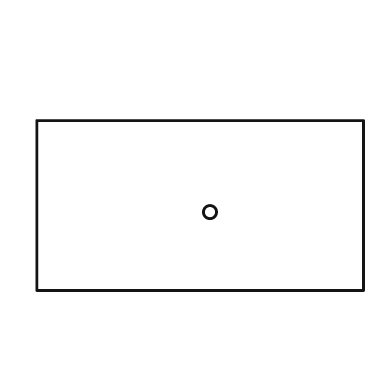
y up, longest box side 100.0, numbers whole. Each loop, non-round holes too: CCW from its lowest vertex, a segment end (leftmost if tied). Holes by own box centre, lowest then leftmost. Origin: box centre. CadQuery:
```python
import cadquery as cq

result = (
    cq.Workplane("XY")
    .moveTo(-50.0, -26.0)
    .lineTo(50.0, -26.0)
    .lineTo(50.0, 26.0)
    .lineTo(-50.0, 26.0)
    .close()
    .moveTo(3.0, -2.0)
    .circle(2.0)
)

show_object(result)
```